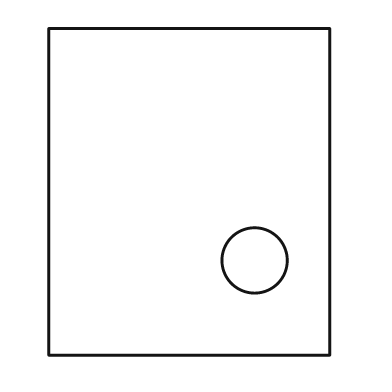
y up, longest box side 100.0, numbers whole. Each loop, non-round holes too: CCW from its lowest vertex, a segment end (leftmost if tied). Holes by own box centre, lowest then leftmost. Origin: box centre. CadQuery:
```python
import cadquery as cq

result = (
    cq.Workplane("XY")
    .moveTo(-43.0, -50.0)
    .lineTo(43.0, -50.0)
    .lineTo(43.0, 50.0)
    .lineTo(-43.0, 50.0)
    .close()
    .moveTo(20.0, -21.0)
    .circle(10.0)
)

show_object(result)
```